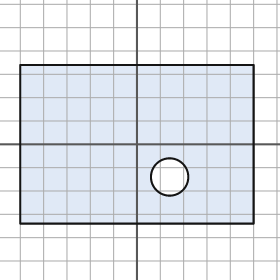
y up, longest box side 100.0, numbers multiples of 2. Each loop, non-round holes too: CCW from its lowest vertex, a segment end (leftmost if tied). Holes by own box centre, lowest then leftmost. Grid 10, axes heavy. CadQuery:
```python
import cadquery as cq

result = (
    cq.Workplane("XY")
    .moveTo(-50.0, -34.0)
    .lineTo(50.0, -34.0)
    .lineTo(50.0, 34.0)
    .lineTo(-50.0, 34.0)
    .close()
    .moveTo(14.0, -14.0)
    .circle(8.0)
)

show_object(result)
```